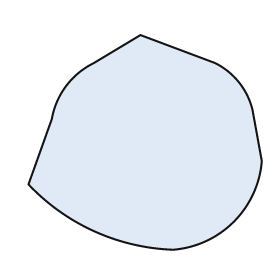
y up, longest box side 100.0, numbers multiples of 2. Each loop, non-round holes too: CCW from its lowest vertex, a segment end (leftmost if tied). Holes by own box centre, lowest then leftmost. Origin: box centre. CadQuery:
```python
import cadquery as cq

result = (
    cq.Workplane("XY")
    .moveTo(12.0, -46.0)
    .threePointArc((38.0, -34.0), (50.0, -8.0))
    .lineTo(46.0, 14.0)
    .threePointArc((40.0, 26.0), (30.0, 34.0))
    .lineTo(-2.0, 46.0)
    .lineTo(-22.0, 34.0)
    .threePointArc((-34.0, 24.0), (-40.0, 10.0))
    .lineTo(-50.0, -18.0)
    .threePointArc((-22.0, -38.0), (12.0, -46.0))
    .close()
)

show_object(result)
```